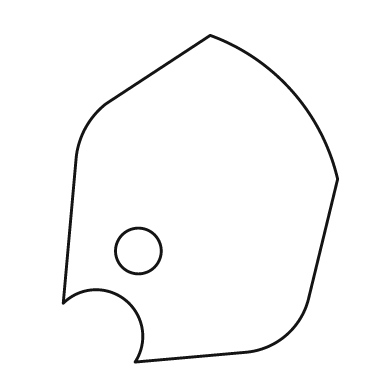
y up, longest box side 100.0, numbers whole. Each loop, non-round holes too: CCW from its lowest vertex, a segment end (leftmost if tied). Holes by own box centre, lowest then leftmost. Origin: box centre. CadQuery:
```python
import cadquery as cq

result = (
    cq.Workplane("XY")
    .moveTo(-20.0, -50.0)
    .lineTo(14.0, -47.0)
    .threePointArc((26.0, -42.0), (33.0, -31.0))
    .lineTo(42.0, 6.0)
    .threePointArc((28.0, 33.0), (3.0, 50.0))
    .lineTo(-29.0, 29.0)
    .threePointArc((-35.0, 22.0), (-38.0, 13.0))
    .lineTo(-42.0, -32.0)
    .threePointArc((-23.0, -31.0), (-20.0, -50.0))
    .close()
    .moveTo(-19.0, -16.0)
    .circle(7.0)
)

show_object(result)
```